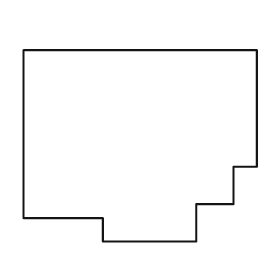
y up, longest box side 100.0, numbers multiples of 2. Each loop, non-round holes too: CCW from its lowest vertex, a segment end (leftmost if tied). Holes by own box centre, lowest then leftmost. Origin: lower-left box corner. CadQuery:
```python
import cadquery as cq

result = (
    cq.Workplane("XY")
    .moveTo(34.0, 0.0)
    .lineTo(74.0, 0.0)
    .lineTo(74.0, 16.0)
    .lineTo(90.0, 16.0)
    .lineTo(90.0, 32.0)
    .lineTo(100.0, 32.0)
    .lineTo(100.0, 82.0)
    .lineTo(0.0, 82.0)
    .lineTo(0.0, 10.0)
    .lineTo(34.0, 10.0)
    .close()
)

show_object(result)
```